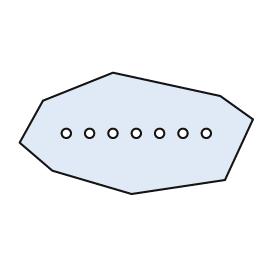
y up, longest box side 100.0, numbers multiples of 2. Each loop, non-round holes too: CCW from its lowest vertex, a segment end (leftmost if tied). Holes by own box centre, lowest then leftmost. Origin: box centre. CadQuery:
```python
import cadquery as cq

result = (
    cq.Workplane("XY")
    .moveTo(-2.0, -26.0)
    .lineTo(38.0, -20.0)
    .lineTo(50.0, 6.0)
    .lineTo(36.0, 16.0)
    .lineTo(-10.0, 26.0)
    .lineTo(-40.0, 14.0)
    .lineTo(-50.0, -4.0)
    .lineTo(-36.0, -16.0)
    .close()
    .moveTo(-30.0, 0.0)
    .circle(2.0)
    .moveTo(-20.0, 0.0)
    .circle(2.0)
    .moveTo(-10.0, 0.0)
    .circle(2.0)
    .moveTo(0.0, 0.0)
    .circle(2.0)
    .moveTo(10.0, 0.0)
    .circle(2.0)
    .moveTo(20.0, 0.0)
    .circle(2.0)
    .moveTo(30.0, 0.0)
    .circle(2.0)
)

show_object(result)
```